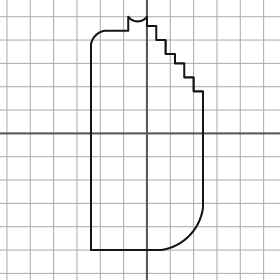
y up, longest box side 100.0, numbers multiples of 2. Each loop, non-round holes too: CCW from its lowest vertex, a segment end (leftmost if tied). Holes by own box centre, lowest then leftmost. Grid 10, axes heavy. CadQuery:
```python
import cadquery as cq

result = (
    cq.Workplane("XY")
    .moveTo(-24.0, -50.0)
    .lineTo(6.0, -50.0)
    .threePointArc((18.0, -44.0), (24.0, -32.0))
    .lineTo(24.0, 18.0)
    .lineTo(20.0, 18.0)
    .lineTo(20.0, 24.0)
    .lineTo(16.0, 24.0)
    .lineTo(16.0, 30.0)
    .lineTo(12.0, 30.0)
    .lineTo(12.0, 34.0)
    .lineTo(8.0, 34.0)
    .lineTo(8.0, 40.0)
    .lineTo(4.0, 40.0)
    .lineTo(4.0, 46.0)
    .lineTo(0.0, 46.0)
    .lineTo(0.0, 50.0)
    .threePointArc((-4.0, 48.0), (-8.0, 50.0))
    .lineTo(-8.0, 44.0)
    .lineTo(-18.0, 44.0)
    .threePointArc((-22.0, 42.0), (-24.0, 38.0))
    .close()
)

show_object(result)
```